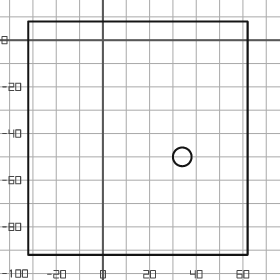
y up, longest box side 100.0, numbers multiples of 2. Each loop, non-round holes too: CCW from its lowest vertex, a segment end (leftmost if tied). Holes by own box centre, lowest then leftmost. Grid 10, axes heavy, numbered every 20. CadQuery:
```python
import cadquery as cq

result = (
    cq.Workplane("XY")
    .moveTo(-32.0, -92.0)
    .lineTo(62.0, -92.0)
    .lineTo(62.0, 8.0)
    .lineTo(-32.0, 8.0)
    .close()
    .moveTo(34.0, -50.0)
    .circle(4.0)
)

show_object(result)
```